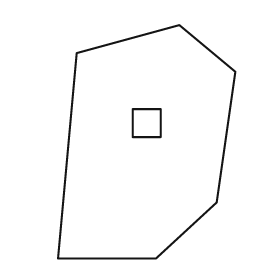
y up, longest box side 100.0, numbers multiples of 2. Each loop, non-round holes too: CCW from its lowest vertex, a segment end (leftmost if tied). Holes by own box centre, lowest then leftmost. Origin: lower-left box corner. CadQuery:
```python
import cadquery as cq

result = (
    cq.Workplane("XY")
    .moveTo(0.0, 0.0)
    .lineTo(42.0, 0.0)
    .lineTo(68.0, 24.0)
    .lineTo(76.0, 80.0)
    .lineTo(52.0, 100.0)
    .lineTo(8.0, 88.0)
    .close()
    .moveTo(32.0, 52.0)
    .lineTo(44.0, 52.0)
    .lineTo(44.0, 64.0)
    .lineTo(32.0, 64.0)
    .close()
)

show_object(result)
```